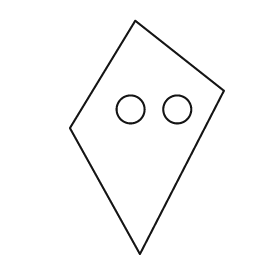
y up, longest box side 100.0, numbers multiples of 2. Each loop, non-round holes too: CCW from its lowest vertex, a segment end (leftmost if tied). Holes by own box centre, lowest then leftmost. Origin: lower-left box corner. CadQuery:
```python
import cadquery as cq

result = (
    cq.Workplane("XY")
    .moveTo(30.0, 0.0)
    .lineTo(66.0, 70.0)
    .lineTo(28.0, 100.0)
    .lineTo(0.0, 54.0)
    .close()
    .moveTo(26.0, 62.0)
    .circle(6.0)
    .moveTo(46.0, 62.0)
    .circle(6.0)
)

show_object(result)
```